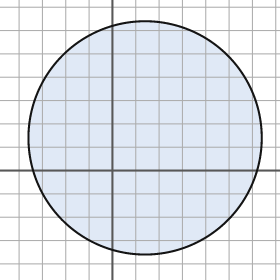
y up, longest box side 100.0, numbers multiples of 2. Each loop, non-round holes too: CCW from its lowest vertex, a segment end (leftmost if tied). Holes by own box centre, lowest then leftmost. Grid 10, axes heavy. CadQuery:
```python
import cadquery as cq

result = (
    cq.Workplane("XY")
    .moveTo(14.0, 14.0)
    .circle(50.0)
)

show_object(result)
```